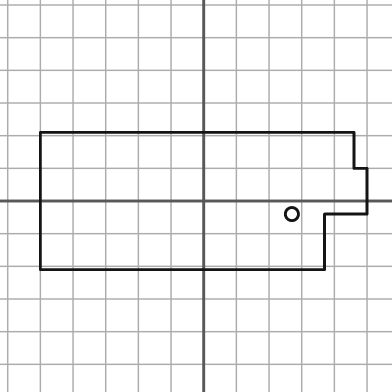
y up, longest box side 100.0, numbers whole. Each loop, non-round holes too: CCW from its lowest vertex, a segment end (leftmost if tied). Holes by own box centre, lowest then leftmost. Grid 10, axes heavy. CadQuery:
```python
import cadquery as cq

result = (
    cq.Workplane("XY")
    .moveTo(-50.0, -21.0)
    .lineTo(37.0, -21.0)
    .lineTo(37.0, -4.0)
    .lineTo(50.0, -4.0)
    .lineTo(50.0, 10.0)
    .lineTo(46.0, 10.0)
    .lineTo(46.0, 21.0)
    .lineTo(-50.0, 21.0)
    .close()
    .moveTo(27.0, -4.0)
    .circle(2.0)
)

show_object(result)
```